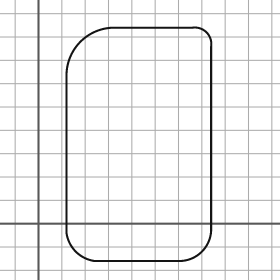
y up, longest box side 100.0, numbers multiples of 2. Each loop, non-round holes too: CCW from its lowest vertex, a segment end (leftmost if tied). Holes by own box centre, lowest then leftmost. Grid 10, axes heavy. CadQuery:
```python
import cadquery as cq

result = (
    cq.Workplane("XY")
    .moveTo(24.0, -16.0)
    .lineTo(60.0, -16.0)
    .threePointArc((70.0, -12.0), (74.0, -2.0))
    .lineTo(74.0, 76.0)
    .threePointArc((72.0, 82.0), (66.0, 84.0))
    .lineTo(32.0, 84.0)
    .threePointArc((18.0, 78.0), (12.0, 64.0))
    .lineTo(12.0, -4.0)
    .threePointArc((16.0, -12.0), (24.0, -16.0))
    .close()
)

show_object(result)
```